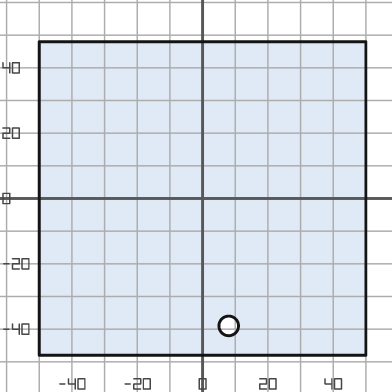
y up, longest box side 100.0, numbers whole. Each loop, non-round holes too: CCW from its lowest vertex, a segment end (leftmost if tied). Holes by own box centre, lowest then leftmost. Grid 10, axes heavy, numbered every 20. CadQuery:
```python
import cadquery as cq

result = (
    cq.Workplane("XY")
    .moveTo(-50.0, -48.0)
    .lineTo(50.0, -48.0)
    .lineTo(50.0, 48.0)
    .lineTo(-50.0, 48.0)
    .close()
    .moveTo(8.0, -39.0)
    .circle(3.0)
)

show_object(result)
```